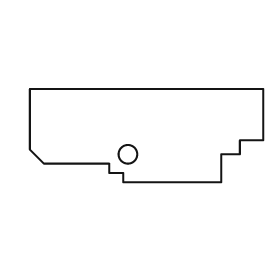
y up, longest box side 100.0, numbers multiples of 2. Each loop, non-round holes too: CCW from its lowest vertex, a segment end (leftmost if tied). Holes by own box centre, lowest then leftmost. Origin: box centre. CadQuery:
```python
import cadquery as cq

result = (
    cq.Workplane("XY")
    .moveTo(-10.0, -20.0)
    .lineTo(32.0, -20.0)
    .lineTo(32.0, -8.0)
    .lineTo(40.0, -8.0)
    .lineTo(40.0, -2.0)
    .lineTo(50.0, -2.0)
    .lineTo(50.0, 20.0)
    .lineTo(-50.0, 20.0)
    .lineTo(-50.0, -6.0)
    .lineTo(-44.0, -12.0)
    .lineTo(-16.0, -12.0)
    .lineTo(-16.0, -16.0)
    .lineTo(-10.0, -16.0)
    .close()
    .moveTo(-8.0, -8.0)
    .circle(4.0)
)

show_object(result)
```